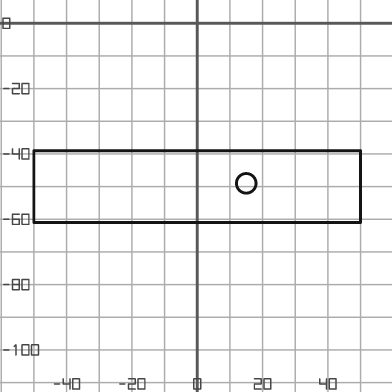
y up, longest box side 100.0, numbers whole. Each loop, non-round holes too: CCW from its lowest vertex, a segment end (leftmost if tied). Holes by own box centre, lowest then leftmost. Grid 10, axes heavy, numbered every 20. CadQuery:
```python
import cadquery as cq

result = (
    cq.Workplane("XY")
    .moveTo(-50.0, -61.0)
    .lineTo(50.0, -61.0)
    .lineTo(50.0, -39.0)
    .lineTo(-50.0, -39.0)
    .close()
    .moveTo(15.0, -49.0)
    .circle(3.0)
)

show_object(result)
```